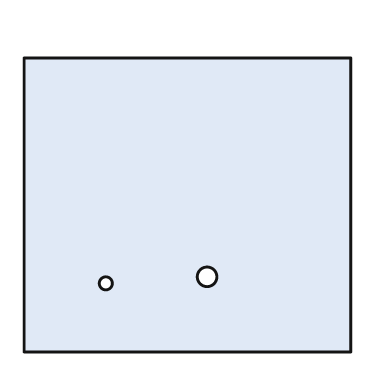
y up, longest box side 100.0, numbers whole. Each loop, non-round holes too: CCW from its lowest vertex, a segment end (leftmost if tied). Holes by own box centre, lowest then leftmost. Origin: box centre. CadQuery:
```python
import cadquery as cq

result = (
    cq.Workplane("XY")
    .moveTo(-50.0, -45.0)
    .lineTo(50.0, -45.0)
    .lineTo(50.0, 45.0)
    .lineTo(-50.0, 45.0)
    .close()
    .moveTo(-25.0, -24.0)
    .circle(2.0)
    .moveTo(6.0, -22.0)
    .circle(3.0)
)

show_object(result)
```